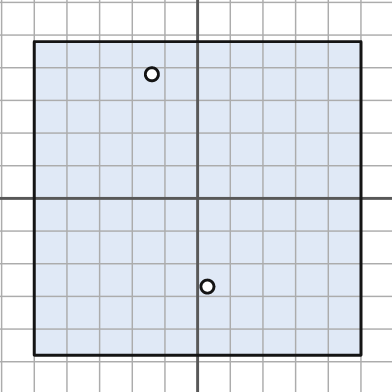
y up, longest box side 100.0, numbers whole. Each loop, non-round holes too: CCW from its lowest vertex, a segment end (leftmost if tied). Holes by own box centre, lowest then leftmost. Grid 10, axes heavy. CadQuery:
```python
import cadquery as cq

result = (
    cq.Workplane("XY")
    .moveTo(-50.0, -48.0)
    .lineTo(50.0, -48.0)
    .lineTo(50.0, 48.0)
    .lineTo(-50.0, 48.0)
    .close()
    .moveTo(3.0, -27.0)
    .circle(2.0)
    .moveTo(-14.0, 38.0)
    .circle(2.0)
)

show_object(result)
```